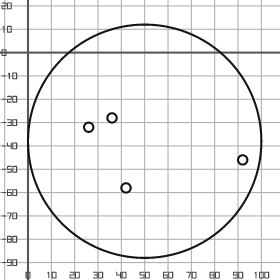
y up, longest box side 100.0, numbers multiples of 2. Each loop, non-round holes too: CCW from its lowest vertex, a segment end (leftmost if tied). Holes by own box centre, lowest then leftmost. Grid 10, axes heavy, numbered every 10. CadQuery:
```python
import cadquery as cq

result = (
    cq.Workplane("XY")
    .moveTo(50.0, -38.0)
    .circle(50.0)
    .moveTo(42.0, -58.0)
    .circle(2.0)
    .moveTo(92.0, -46.0)
    .circle(2.0)
    .moveTo(26.0, -32.0)
    .circle(2.0)
    .moveTo(36.0, -28.0)
    .circle(2.0)
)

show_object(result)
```